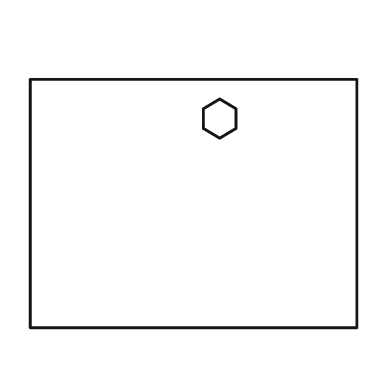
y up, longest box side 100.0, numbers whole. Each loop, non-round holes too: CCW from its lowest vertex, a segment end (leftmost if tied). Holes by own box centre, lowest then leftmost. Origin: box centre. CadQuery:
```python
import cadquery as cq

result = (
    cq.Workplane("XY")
    .moveTo(-50.0, -38.0)
    .lineTo(50.0, -38.0)
    .lineTo(50.0, 38.0)
    .lineTo(-50.0, 38.0)
    .close()
    .moveTo(8.0, 20.0)
    .lineTo(13.0, 23.0)
    .lineTo(13.0, 29.0)
    .lineTo(8.0, 32.0)
    .lineTo(3.0, 29.0)
    .lineTo(3.0, 23.0)
    .close()
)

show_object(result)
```